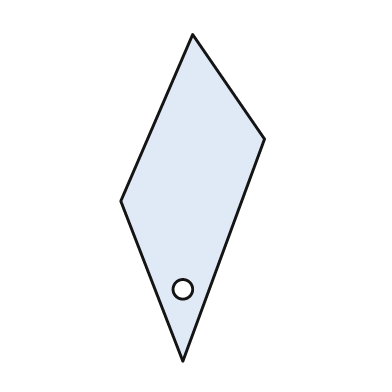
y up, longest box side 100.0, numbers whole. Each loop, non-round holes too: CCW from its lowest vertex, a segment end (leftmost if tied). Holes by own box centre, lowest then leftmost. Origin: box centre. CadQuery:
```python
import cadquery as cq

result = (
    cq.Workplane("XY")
    .moveTo(-3.0, -50.0)
    .lineTo(22.0, 18.0)
    .lineTo(0.0, 50.0)
    .lineTo(-22.0, -1.0)
    .close()
    .moveTo(-3.0, -28.0)
    .circle(3.0)
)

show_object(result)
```